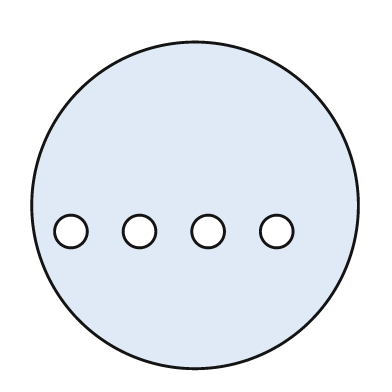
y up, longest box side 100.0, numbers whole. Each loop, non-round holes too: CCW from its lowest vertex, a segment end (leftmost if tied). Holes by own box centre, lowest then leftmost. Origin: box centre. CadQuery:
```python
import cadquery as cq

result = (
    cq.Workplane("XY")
    .moveTo(0.0, 0.0)
    .circle(50.0)
    .moveTo(-38.0, -8.0)
    .circle(5.0)
    .moveTo(-17.0, -8.0)
    .circle(5.0)
    .moveTo(4.0, -8.0)
    .circle(5.0)
    .moveTo(25.0, -8.0)
    .circle(5.0)
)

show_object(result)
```